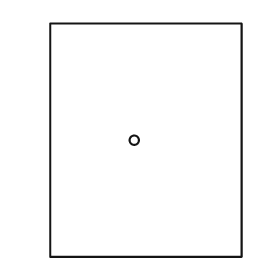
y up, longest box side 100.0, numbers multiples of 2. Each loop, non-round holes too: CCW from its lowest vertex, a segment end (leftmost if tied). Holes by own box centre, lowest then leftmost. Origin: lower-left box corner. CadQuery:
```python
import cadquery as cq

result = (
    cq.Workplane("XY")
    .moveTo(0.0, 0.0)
    .lineTo(82.0, 0.0)
    .lineTo(82.0, 100.0)
    .lineTo(0.0, 100.0)
    .close()
    .moveTo(36.0, 50.0)
    .circle(2.0)
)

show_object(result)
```